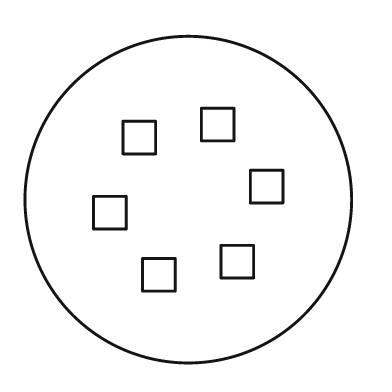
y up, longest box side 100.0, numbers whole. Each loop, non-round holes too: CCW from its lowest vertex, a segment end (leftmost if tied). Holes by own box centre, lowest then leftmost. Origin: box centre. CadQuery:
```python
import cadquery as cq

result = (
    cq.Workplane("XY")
    .moveTo(0.0, 0.0)
    .circle(50.0)
    .moveTo(-14.0, -28.0)
    .lineTo(-4.0, -28.0)
    .lineTo(-4.0, -18.0)
    .lineTo(-14.0, -18.0)
    .close()
    .moveTo(10.0, -24.0)
    .lineTo(20.0, -24.0)
    .lineTo(20.0, -14.0)
    .lineTo(10.0, -14.0)
    .close()
    .moveTo(-29.0, -9.0)
    .lineTo(-19.0, -9.0)
    .lineTo(-19.0, 1.0)
    .lineTo(-29.0, 1.0)
    .close()
    .moveTo(19.0, -1.0)
    .lineTo(29.0, -1.0)
    .lineTo(29.0, 9.0)
    .lineTo(19.0, 9.0)
    .close()
    .moveTo(-20.0, 14.0)
    .lineTo(-10.0, 14.0)
    .lineTo(-10.0, 24.0)
    .lineTo(-20.0, 24.0)
    .close()
    .moveTo(4.0, 18.0)
    .lineTo(14.0, 18.0)
    .lineTo(14.0, 28.0)
    .lineTo(4.0, 28.0)
    .close()
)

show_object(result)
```